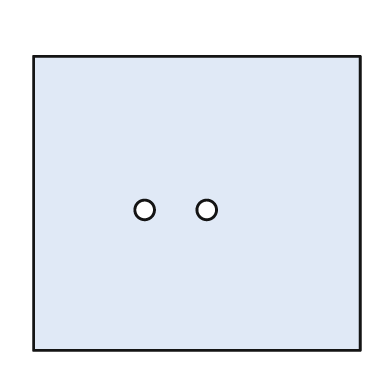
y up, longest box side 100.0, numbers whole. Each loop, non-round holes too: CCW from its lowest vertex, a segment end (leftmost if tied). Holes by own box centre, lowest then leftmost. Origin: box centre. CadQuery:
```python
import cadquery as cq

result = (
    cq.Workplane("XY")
    .moveTo(-50.0, -45.0)
    .lineTo(50.0, -45.0)
    .lineTo(50.0, 45.0)
    .lineTo(-50.0, 45.0)
    .close()
    .moveTo(-16.0, -2.0)
    .circle(3.0)
    .moveTo(3.0, -2.0)
    .circle(3.0)
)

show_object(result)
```